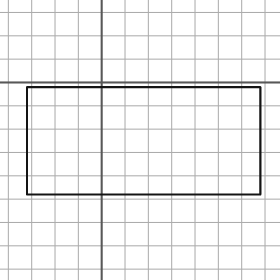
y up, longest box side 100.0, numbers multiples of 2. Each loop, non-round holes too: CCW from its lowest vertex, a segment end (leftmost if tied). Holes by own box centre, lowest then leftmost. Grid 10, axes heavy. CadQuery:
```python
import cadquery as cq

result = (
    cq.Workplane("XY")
    .moveTo(-32.0, -48.0)
    .lineTo(68.0, -48.0)
    .lineTo(68.0, -2.0)
    .lineTo(-32.0, -2.0)
    .close()
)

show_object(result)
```